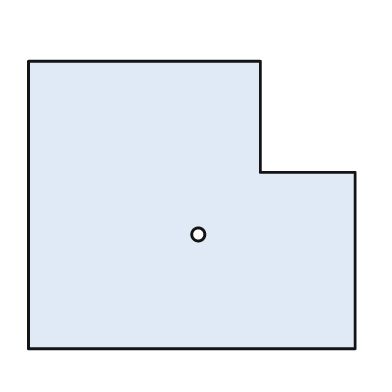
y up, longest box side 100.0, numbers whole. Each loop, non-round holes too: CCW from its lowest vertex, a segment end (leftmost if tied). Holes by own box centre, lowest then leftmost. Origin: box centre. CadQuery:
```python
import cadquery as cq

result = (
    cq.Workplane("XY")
    .moveTo(-50.0, -44.0)
    .lineTo(50.0, -44.0)
    .lineTo(50.0, 10.0)
    .lineTo(21.0, 10.0)
    .lineTo(21.0, 44.0)
    .lineTo(-50.0, 44.0)
    .close()
    .moveTo(2.0, -9.0)
    .circle(2.0)
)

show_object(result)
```